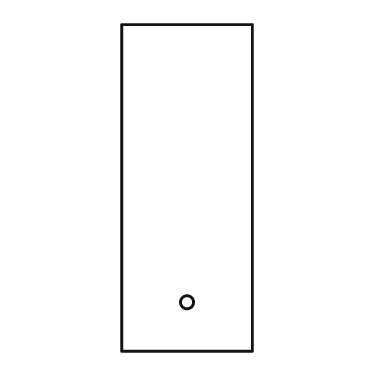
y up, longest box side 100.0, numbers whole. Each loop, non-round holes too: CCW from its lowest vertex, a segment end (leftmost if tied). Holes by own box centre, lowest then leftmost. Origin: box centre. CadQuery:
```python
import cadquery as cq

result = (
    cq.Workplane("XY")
    .moveTo(-20.0, -50.0)
    .lineTo(20.0, -50.0)
    .lineTo(20.0, 50.0)
    .lineTo(-20.0, 50.0)
    .close()
    .moveTo(0.0, -35.0)
    .circle(2.0)
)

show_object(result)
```